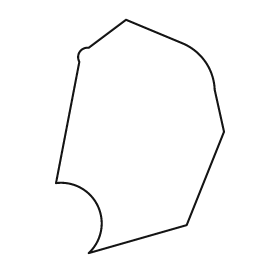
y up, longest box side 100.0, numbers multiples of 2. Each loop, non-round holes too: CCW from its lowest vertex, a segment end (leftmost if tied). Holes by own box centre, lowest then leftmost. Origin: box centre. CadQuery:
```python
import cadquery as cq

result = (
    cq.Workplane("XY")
    .moveTo(-22.0, -50.0)
    .lineTo(20.0, -38.0)
    .lineTo(36.0, 2.0)
    .lineTo(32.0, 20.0)
    .threePointArc((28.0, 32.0), (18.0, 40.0))
    .lineTo(-6.0, 50.0)
    .lineTo(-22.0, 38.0)
    .threePointArc((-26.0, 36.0), (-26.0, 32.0))
    .lineTo(-36.0, -20.0)
    .threePointArc((-18.0, -30.0), (-22.0, -50.0))
    .close()
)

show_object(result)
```